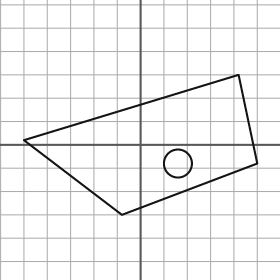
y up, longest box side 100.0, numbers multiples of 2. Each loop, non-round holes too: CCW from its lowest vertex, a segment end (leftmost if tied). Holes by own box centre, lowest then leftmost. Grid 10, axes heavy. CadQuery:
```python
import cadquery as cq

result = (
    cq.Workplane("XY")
    .moveTo(-8.0, -30.0)
    .lineTo(50.0, -8.0)
    .lineTo(42.0, 30.0)
    .lineTo(-50.0, 2.0)
    .close()
    .moveTo(16.0, -8.0)
    .circle(6.0)
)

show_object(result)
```